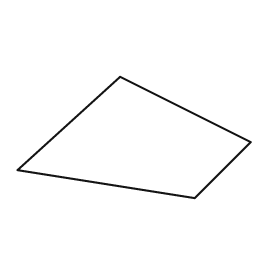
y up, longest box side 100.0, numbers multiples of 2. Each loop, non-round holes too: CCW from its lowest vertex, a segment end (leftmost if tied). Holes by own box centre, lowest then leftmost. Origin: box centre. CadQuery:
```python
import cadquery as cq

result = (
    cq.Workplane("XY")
    .moveTo(26.0, -26.0)
    .lineTo(50.0, -2.0)
    .lineTo(-6.0, 26.0)
    .lineTo(-50.0, -14.0)
    .close()
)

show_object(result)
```